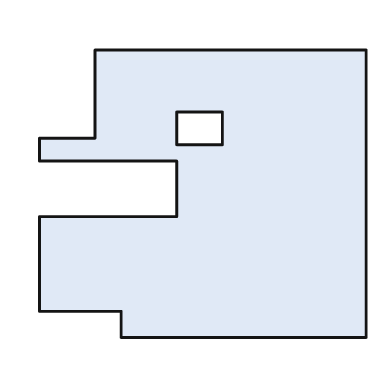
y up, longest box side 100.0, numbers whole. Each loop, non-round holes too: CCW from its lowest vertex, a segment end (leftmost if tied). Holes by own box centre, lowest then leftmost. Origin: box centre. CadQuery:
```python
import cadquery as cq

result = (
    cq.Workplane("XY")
    .moveTo(-25.0, -44.0)
    .lineTo(50.0, -44.0)
    .lineTo(50.0, 44.0)
    .lineTo(-33.0, 44.0)
    .lineTo(-33.0, 17.0)
    .lineTo(-50.0, 17.0)
    .lineTo(-50.0, 10.0)
    .lineTo(-8.0, 10.0)
    .lineTo(-8.0, -7.0)
    .lineTo(-50.0, -7.0)
    .lineTo(-50.0, -36.0)
    .lineTo(-25.0, -36.0)
    .close()
    .moveTo(-8.0, 15.0)
    .lineTo(6.0, 15.0)
    .lineTo(6.0, 25.0)
    .lineTo(-8.0, 25.0)
    .close()
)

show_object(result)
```